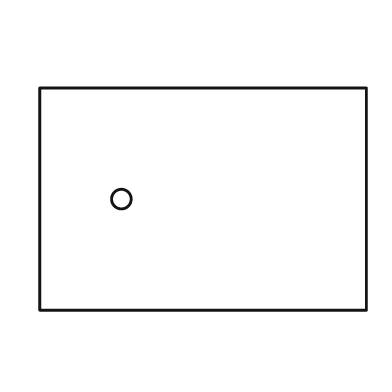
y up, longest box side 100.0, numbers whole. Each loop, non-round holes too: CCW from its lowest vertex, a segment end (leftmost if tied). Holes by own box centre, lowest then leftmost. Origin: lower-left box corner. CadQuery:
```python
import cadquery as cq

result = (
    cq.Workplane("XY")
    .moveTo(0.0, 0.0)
    .lineTo(100.0, 0.0)
    .lineTo(100.0, 68.0)
    .lineTo(0.0, 68.0)
    .close()
    .moveTo(25.0, 34.0)
    .circle(3.0)
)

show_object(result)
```